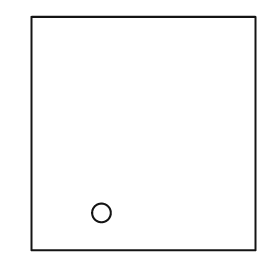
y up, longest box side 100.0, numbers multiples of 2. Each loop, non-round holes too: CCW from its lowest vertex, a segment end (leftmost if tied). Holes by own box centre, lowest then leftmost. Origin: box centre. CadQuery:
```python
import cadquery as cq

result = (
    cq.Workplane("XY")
    .moveTo(-48.0, -50.0)
    .lineTo(48.0, -50.0)
    .lineTo(48.0, 50.0)
    .lineTo(-48.0, 50.0)
    .close()
    .moveTo(-18.0, -34.0)
    .circle(4.0)
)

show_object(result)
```